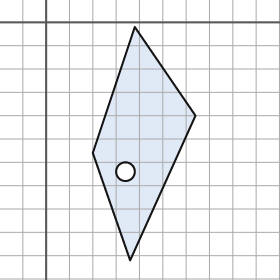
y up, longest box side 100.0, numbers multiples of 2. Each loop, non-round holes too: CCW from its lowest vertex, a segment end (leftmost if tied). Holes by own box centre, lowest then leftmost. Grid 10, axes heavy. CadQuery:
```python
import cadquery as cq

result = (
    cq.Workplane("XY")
    .moveTo(36.0, -102.0)
    .lineTo(64.0, -40.0)
    .lineTo(38.0, -2.0)
    .lineTo(20.0, -56.0)
    .close()
    .moveTo(34.0, -64.0)
    .circle(4.0)
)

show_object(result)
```